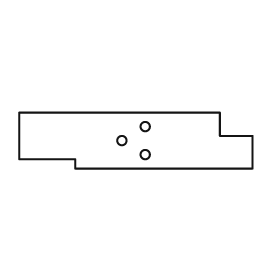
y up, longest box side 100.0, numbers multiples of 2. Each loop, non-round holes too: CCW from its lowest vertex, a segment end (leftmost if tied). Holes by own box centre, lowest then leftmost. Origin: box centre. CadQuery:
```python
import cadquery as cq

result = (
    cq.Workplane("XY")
    .moveTo(-26.0, -12.0)
    .lineTo(50.0, -12.0)
    .lineTo(50.0, 2.0)
    .lineTo(36.0, 2.0)
    .lineTo(36.0, 12.0)
    .lineTo(-50.0, 12.0)
    .lineTo(-50.0, -8.0)
    .lineTo(-26.0, -8.0)
    .close()
    .moveTo(4.0, -6.0)
    .circle(2.0)
    .moveTo(-6.0, 0.0)
    .circle(2.0)
    .moveTo(4.0, 6.0)
    .circle(2.0)
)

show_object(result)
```